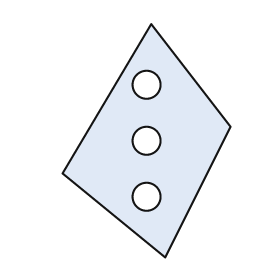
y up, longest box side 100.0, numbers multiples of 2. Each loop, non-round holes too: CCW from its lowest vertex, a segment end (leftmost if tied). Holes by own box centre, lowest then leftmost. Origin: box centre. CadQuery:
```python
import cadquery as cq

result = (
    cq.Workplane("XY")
    .moveTo(8.0, -50.0)
    .lineTo(36.0, 6.0)
    .lineTo(2.0, 50.0)
    .lineTo(-36.0, -14.0)
    .close()
    .moveTo(0.0, -24.0)
    .circle(6.0)
    .moveTo(0.0, 0.0)
    .circle(6.0)
    .moveTo(0.0, 24.0)
    .circle(6.0)
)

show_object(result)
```